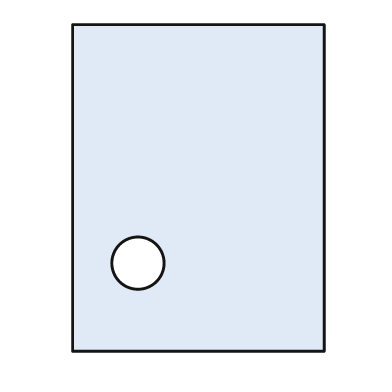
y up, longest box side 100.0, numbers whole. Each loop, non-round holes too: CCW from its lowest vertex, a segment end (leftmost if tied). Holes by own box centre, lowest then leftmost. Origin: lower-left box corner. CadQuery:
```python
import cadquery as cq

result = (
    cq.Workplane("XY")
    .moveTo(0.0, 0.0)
    .lineTo(77.0, 0.0)
    .lineTo(77.0, 100.0)
    .lineTo(0.0, 100.0)
    .close()
    .moveTo(20.0, 27.0)
    .circle(8.0)
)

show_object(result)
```